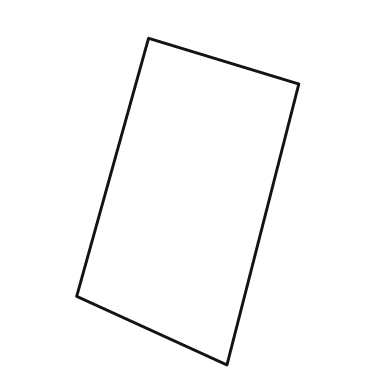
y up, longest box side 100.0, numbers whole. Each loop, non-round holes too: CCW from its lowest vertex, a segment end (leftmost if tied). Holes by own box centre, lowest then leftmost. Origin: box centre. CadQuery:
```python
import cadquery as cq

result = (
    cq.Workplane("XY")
    .moveTo(12.0, -50.0)
    .lineTo(34.0, 36.0)
    .lineTo(-12.0, 50.0)
    .lineTo(-34.0, -29.0)
    .close()
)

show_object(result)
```